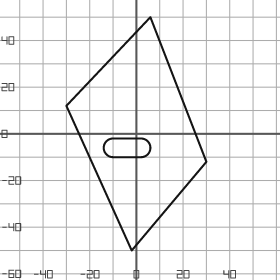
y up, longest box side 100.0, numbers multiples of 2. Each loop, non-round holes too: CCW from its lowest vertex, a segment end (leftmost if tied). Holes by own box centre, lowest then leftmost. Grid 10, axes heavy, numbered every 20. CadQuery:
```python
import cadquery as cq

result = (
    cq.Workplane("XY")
    .moveTo(-2.0, -50.0)
    .lineTo(30.0, -12.0)
    .lineTo(6.0, 50.0)
    .lineTo(-30.0, 12.0)
    .close()
    .moveTo(-10.0, -10.0)
    .lineTo(2.0, -10.0)
    .threePointArc((6.0, -6.0), (2.0, -2.0))
    .lineTo(-10.0, -2.0)
    .threePointArc((-14.0, -6.0), (-10.0, -10.0))
    .close()
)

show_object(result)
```